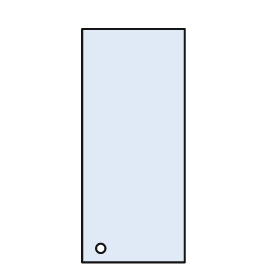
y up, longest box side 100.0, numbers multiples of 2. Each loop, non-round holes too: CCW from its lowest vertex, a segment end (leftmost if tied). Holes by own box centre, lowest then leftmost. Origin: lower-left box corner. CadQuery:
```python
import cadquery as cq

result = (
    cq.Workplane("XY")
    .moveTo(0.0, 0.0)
    .lineTo(44.0, 0.0)
    .lineTo(44.0, 100.0)
    .lineTo(0.0, 100.0)
    .close()
    .moveTo(8.0, 6.0)
    .circle(2.0)
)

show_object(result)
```